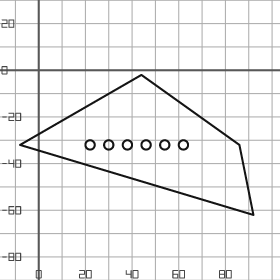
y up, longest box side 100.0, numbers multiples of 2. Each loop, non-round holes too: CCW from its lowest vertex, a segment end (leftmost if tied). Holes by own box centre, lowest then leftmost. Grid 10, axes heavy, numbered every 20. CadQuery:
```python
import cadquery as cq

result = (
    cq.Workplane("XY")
    .moveTo(92.0, -62.0)
    .lineTo(86.0, -32.0)
    .lineTo(44.0, -2.0)
    .lineTo(-8.0, -32.0)
    .close()
    .moveTo(22.0, -32.0)
    .circle(2.0)
    .moveTo(30.0, -32.0)
    .circle(2.0)
    .moveTo(38.0, -32.0)
    .circle(2.0)
    .moveTo(46.0, -32.0)
    .circle(2.0)
    .moveTo(54.0, -32.0)
    .circle(2.0)
    .moveTo(62.0, -32.0)
    .circle(2.0)
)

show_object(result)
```